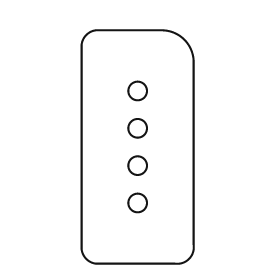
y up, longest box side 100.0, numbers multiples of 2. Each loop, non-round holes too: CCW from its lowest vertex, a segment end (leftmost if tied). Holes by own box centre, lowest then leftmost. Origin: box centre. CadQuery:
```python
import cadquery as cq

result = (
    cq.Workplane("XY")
    .moveTo(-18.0, -50.0)
    .lineTo(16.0, -50.0)
    .threePointArc((22.0, -48.0), (24.0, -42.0))
    .lineTo(24.0, 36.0)
    .threePointArc((20.0, 46.0), (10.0, 50.0))
    .lineTo(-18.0, 50.0)
    .threePointArc((-22.0, 48.0), (-24.0, 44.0))
    .lineTo(-24.0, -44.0)
    .threePointArc((-22.0, -48.0), (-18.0, -50.0))
    .close()
    .moveTo(0.0, -24.0)
    .circle(4.0)
    .moveTo(0.0, -8.0)
    .circle(4.0)
    .moveTo(0.0, 8.0)
    .circle(4.0)
    .moveTo(0.0, 24.0)
    .circle(4.0)
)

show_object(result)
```